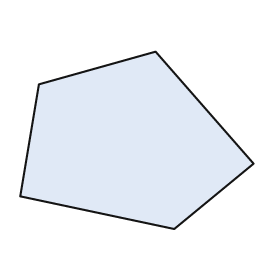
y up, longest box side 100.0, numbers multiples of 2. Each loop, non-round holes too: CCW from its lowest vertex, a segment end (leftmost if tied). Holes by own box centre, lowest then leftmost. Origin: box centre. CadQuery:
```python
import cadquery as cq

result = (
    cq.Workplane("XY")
    .moveTo(16.0, -38.0)
    .lineTo(50.0, -10.0)
    .lineTo(8.0, 38.0)
    .lineTo(-42.0, 24.0)
    .lineTo(-50.0, -24.0)
    .close()
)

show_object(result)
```